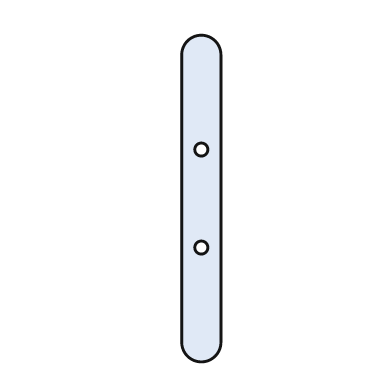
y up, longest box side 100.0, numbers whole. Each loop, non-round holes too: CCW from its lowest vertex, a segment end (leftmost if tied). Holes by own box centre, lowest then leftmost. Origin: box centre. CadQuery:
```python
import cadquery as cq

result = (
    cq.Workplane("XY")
    .moveTo(-6.0, -44.0)
    .threePointArc((0.0, -50.0), (6.0, -44.0))
    .lineTo(6.0, 44.0)
    .threePointArc((0.0, 50.0), (-6.0, 44.0))
    .close()
    .moveTo(0.0, -15.0)
    .circle(2.0)
    .moveTo(0.0, 15.0)
    .circle(2.0)
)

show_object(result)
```